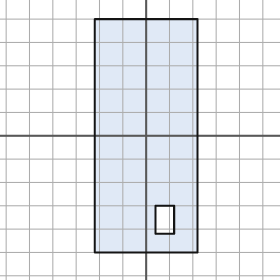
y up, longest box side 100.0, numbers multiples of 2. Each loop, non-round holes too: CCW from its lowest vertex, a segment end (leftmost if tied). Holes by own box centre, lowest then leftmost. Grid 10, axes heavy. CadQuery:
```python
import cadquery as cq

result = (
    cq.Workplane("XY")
    .moveTo(-22.0, -50.0)
    .lineTo(22.0, -50.0)
    .lineTo(22.0, 50.0)
    .lineTo(-22.0, 50.0)
    .close()
    .moveTo(4.0, -42.0)
    .lineTo(12.0, -42.0)
    .lineTo(12.0, -30.0)
    .lineTo(4.0, -30.0)
    .close()
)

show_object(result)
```